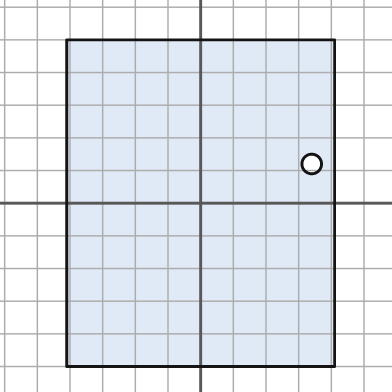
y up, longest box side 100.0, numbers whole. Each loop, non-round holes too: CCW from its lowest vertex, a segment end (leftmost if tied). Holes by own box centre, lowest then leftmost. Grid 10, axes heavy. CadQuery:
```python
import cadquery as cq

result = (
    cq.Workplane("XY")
    .moveTo(-41.0, -50.0)
    .lineTo(41.0, -50.0)
    .lineTo(41.0, 50.0)
    .lineTo(-41.0, 50.0)
    .close()
    .moveTo(34.0, 12.0)
    .circle(3.0)
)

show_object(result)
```